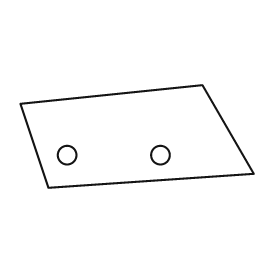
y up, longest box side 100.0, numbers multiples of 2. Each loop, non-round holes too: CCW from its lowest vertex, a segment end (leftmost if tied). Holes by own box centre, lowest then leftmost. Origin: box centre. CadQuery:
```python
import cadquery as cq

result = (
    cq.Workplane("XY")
    .moveTo(-38.0, -22.0)
    .lineTo(50.0, -16.0)
    .lineTo(28.0, 22.0)
    .lineTo(-50.0, 14.0)
    .close()
    .moveTo(-30.0, -8.0)
    .circle(4.0)
    .moveTo(10.0, -8.0)
    .circle(4.0)
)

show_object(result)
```